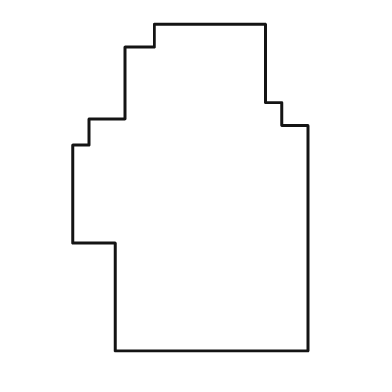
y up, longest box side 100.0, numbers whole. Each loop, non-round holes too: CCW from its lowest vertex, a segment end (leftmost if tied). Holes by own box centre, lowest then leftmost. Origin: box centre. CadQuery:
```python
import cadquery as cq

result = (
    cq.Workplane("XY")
    .moveTo(-23.0, -50.0)
    .lineTo(36.0, -50.0)
    .lineTo(36.0, 19.0)
    .lineTo(28.0, 19.0)
    .lineTo(28.0, 26.0)
    .lineTo(23.0, 26.0)
    .lineTo(23.0, 50.0)
    .lineTo(-11.0, 50.0)
    .lineTo(-11.0, 43.0)
    .lineTo(-20.0, 43.0)
    .lineTo(-20.0, 21.0)
    .lineTo(-31.0, 21.0)
    .lineTo(-31.0, 13.0)
    .lineTo(-36.0, 13.0)
    .lineTo(-36.0, -17.0)
    .lineTo(-23.0, -17.0)
    .close()
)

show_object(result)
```